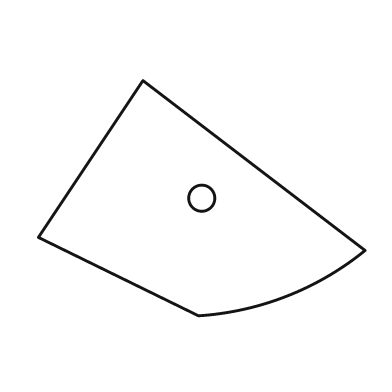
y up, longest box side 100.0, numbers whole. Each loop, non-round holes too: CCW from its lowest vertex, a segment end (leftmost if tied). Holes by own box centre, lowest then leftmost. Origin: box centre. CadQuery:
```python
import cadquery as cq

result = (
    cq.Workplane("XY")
    .moveTo(-1.0, -36.0)
    .threePointArc((26.0, -30.0), (50.0, -16.0))
    .lineTo(-18.0, 36.0)
    .lineTo(-50.0, -12.0)
    .close()
    .moveTo(0.0, 0.0)
    .circle(4.0)
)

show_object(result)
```